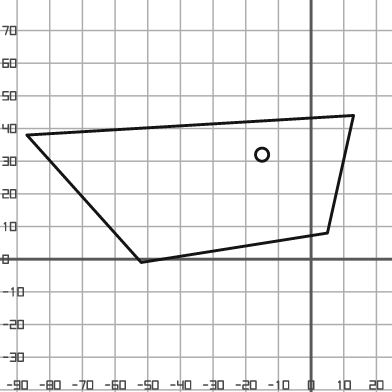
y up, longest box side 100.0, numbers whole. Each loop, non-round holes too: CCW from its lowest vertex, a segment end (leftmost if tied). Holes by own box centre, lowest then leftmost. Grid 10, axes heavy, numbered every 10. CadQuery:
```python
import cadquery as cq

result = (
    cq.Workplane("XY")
    .moveTo(-52.0, -1.0)
    .lineTo(5.0, 8.0)
    .lineTo(13.0, 44.0)
    .lineTo(-87.0, 38.0)
    .close()
    .moveTo(-15.0, 32.0)
    .circle(2.0)
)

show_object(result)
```